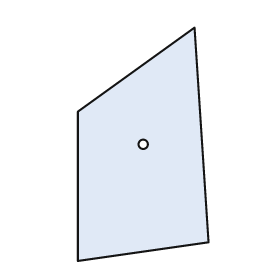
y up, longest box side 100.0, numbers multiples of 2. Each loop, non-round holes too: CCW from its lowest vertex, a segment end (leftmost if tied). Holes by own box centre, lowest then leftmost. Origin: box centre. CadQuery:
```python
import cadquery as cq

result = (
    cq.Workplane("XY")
    .moveTo(-28.0, -50.0)
    .lineTo(28.0, -42.0)
    .lineTo(22.0, 50.0)
    .lineTo(-28.0, 14.0)
    .close()
    .moveTo(0.0, 0.0)
    .circle(2.0)
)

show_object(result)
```